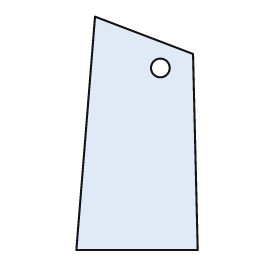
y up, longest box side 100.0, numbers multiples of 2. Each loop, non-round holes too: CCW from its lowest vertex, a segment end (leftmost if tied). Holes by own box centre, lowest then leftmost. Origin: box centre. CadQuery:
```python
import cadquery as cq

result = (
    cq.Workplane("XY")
    .moveTo(-26.0, -50.0)
    .lineTo(26.0, -50.0)
    .lineTo(24.0, 34.0)
    .lineTo(-18.0, 50.0)
    .close()
    .moveTo(10.0, 28.0)
    .circle(4.0)
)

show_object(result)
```